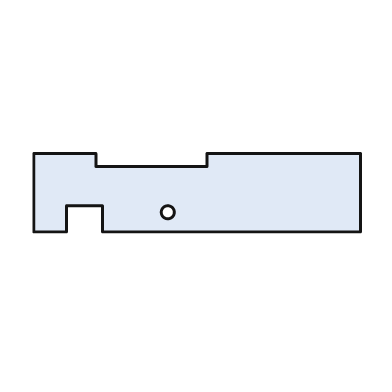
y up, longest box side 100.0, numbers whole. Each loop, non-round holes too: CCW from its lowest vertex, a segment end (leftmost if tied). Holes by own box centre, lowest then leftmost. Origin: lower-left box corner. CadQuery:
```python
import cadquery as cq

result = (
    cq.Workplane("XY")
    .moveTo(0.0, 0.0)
    .lineTo(10.0, 0.0)
    .lineTo(10.0, 8.0)
    .lineTo(21.0, 8.0)
    .lineTo(21.0, 0.0)
    .lineTo(100.0, 0.0)
    .lineTo(100.0, 24.0)
    .lineTo(53.0, 24.0)
    .lineTo(53.0, 20.0)
    .lineTo(19.0, 20.0)
    .lineTo(19.0, 24.0)
    .lineTo(0.0, 24.0)
    .close()
    .moveTo(41.0, 6.0)
    .circle(2.0)
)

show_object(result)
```